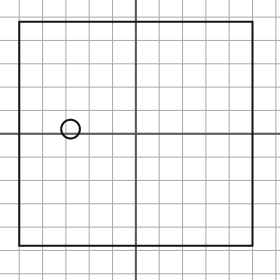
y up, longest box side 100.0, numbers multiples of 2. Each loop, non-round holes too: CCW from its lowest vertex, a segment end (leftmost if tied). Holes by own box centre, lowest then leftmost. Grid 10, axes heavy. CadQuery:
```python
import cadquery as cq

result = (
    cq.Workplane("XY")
    .moveTo(-50.0, -48.0)
    .lineTo(50.0, -48.0)
    .lineTo(50.0, 48.0)
    .lineTo(-50.0, 48.0)
    .close()
    .moveTo(-28.0, 2.0)
    .circle(4.0)
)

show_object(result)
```